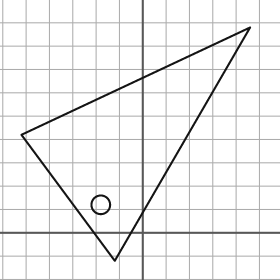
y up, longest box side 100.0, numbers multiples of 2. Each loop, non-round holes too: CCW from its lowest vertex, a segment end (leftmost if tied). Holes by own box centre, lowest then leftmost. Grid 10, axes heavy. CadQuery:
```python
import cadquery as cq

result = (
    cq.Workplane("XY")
    .moveTo(-12.0, -12.0)
    .lineTo(46.0, 88.0)
    .lineTo(-52.0, 42.0)
    .close()
    .moveTo(-18.0, 12.0)
    .circle(4.0)
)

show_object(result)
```